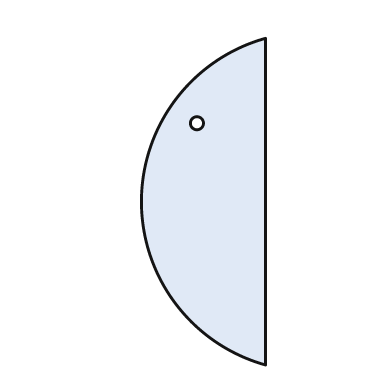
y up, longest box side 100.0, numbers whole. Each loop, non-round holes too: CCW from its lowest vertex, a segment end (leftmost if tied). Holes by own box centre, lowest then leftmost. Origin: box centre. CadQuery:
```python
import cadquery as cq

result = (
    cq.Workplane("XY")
    .moveTo(19.0, -50.0)
    .lineTo(19.0, 50.0)
    .threePointArc((-19.0, 0.0), (19.0, -50.0))
    .close()
    .moveTo(-2.0, 24.0)
    .circle(2.0)
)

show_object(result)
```